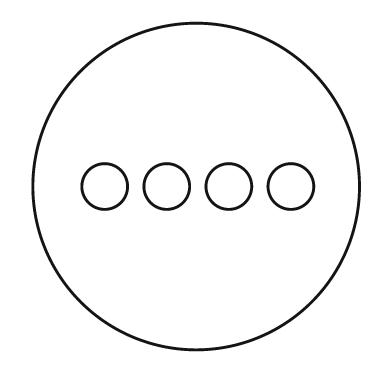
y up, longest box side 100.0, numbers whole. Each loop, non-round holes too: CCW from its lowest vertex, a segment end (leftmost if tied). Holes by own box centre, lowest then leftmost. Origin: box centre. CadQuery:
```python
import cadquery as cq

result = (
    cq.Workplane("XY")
    .moveTo(0.0, 0.0)
    .circle(50.0)
    .moveTo(-28.0, 0.0)
    .circle(7.0)
    .moveTo(-9.0, 0.0)
    .circle(7.0)
    .moveTo(10.0, 0.0)
    .circle(7.0)
    .moveTo(29.0, 0.0)
    .circle(7.0)
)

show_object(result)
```